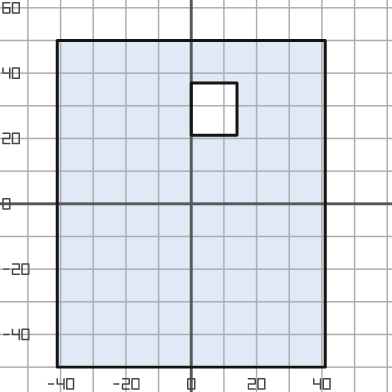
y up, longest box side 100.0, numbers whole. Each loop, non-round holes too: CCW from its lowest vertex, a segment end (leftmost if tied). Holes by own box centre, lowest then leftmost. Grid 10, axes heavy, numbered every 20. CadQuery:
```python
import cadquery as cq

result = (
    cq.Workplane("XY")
    .moveTo(-41.0, -50.0)
    .lineTo(41.0, -50.0)
    .lineTo(41.0, 50.0)
    .lineTo(-41.0, 50.0)
    .close()
    .moveTo(0.0, 21.0)
    .lineTo(14.0, 21.0)
    .lineTo(14.0, 37.0)
    .lineTo(0.0, 37.0)
    .close()
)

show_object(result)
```